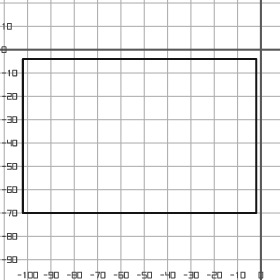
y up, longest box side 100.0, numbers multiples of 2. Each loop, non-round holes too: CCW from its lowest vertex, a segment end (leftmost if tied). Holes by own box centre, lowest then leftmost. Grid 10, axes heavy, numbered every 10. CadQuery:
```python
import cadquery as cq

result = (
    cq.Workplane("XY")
    .moveTo(-102.0, -70.0)
    .lineTo(-2.0, -70.0)
    .lineTo(-2.0, -4.0)
    .lineTo(-102.0, -4.0)
    .close()
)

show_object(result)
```